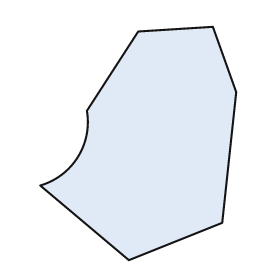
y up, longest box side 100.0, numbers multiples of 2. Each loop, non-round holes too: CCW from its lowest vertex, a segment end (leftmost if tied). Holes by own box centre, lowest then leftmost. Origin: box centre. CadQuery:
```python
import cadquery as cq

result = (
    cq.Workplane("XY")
    .moveTo(-4.0, -50.0)
    .lineTo(36.0, -34.0)
    .lineTo(42.0, 22.0)
    .lineTo(32.0, 50.0)
    .lineTo(0.0, 48.0)
    .lineTo(-22.0, 14.0)
    .threePointArc((-26.0, -6.0), (-42.0, -18.0))
    .close()
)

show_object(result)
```